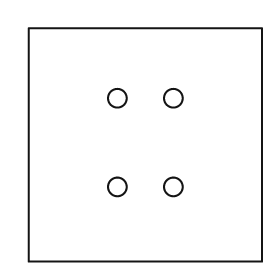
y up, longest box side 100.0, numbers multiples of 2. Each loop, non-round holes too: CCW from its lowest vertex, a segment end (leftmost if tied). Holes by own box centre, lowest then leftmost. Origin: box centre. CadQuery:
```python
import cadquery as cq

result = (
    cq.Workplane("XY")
    .moveTo(-50.0, -50.0)
    .lineTo(50.0, -50.0)
    .lineTo(50.0, 50.0)
    .lineTo(-50.0, 50.0)
    .close()
    .moveTo(-12.0, -18.0)
    .circle(4.0)
    .moveTo(12.0, -18.0)
    .circle(4.0)
    .moveTo(-12.0, 20.0)
    .circle(4.0)
    .moveTo(12.0, 20.0)
    .circle(4.0)
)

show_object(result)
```